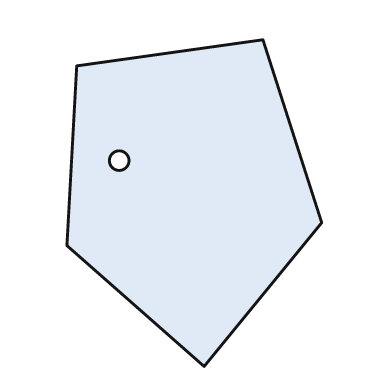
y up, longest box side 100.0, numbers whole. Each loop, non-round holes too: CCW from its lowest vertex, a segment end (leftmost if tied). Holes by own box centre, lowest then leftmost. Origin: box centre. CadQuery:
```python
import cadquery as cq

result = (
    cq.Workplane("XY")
    .moveTo(3.0, -50.0)
    .lineTo(39.0, -6.0)
    .lineTo(21.0, 50.0)
    .lineTo(-36.0, 42.0)
    .lineTo(-39.0, -13.0)
    .close()
    .moveTo(-23.0, 13.0)
    .circle(3.0)
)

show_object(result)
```